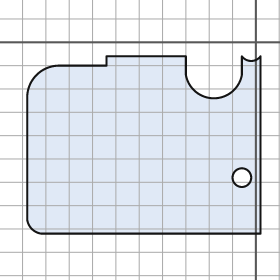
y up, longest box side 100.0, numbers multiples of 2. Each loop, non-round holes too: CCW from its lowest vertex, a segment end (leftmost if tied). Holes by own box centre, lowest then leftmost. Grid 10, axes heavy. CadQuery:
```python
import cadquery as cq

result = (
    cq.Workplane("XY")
    .moveTo(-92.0, -82.0)
    .lineTo(2.0, -82.0)
    .lineTo(2.0, -6.0)
    .threePointArc((-2.0, -8.0), (-6.0, -6.0))
    .lineTo(-6.0, -14.0)
    .threePointArc((-18.0, -24.0), (-30.0, -14.0))
    .lineTo(-30.0, -6.0)
    .lineTo(-64.0, -6.0)
    .lineTo(-64.0, -10.0)
    .lineTo(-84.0, -10.0)
    .threePointArc((-94.0, -14.0), (-98.0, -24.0))
    .lineTo(-98.0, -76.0)
    .threePointArc((-96.0, -80.0), (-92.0, -82.0))
    .close()
    .moveTo(-6.0, -58.0)
    .circle(4.0)
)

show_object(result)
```